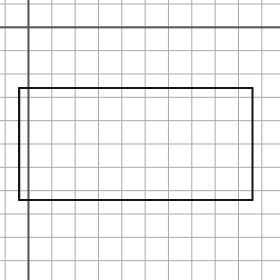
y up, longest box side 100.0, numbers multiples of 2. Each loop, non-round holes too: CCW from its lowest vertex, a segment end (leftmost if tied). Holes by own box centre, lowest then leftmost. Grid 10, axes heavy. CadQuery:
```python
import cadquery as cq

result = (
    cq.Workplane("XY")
    .moveTo(-4.0, -74.0)
    .lineTo(96.0, -74.0)
    .lineTo(96.0, -26.0)
    .lineTo(-4.0, -26.0)
    .close()
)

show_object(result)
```